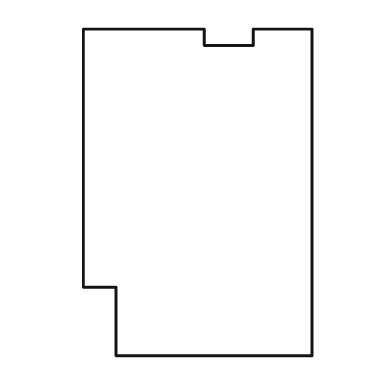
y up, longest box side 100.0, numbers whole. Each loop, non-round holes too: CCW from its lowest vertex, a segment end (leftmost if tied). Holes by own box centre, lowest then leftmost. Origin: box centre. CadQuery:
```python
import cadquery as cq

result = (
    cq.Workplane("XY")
    .moveTo(-25.0, -50.0)
    .lineTo(35.0, -50.0)
    .lineTo(35.0, 50.0)
    .lineTo(17.0, 50.0)
    .lineTo(17.0, 45.0)
    .lineTo(2.0, 45.0)
    .lineTo(2.0, 50.0)
    .lineTo(-35.0, 50.0)
    .lineTo(-35.0, -29.0)
    .lineTo(-25.0, -29.0)
    .close()
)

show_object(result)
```